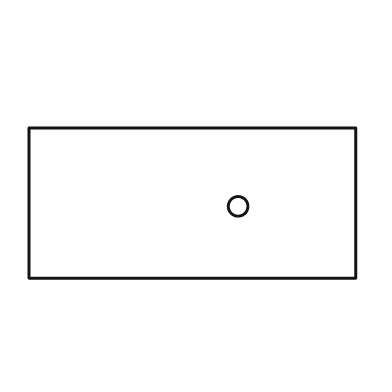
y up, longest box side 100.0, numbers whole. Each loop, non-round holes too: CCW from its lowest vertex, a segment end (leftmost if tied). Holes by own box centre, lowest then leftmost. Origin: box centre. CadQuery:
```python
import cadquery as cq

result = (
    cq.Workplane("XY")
    .moveTo(-50.0, -23.0)
    .lineTo(50.0, -23.0)
    .lineTo(50.0, 23.0)
    .lineTo(-50.0, 23.0)
    .close()
    .moveTo(14.0, -1.0)
    .circle(3.0)
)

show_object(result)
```